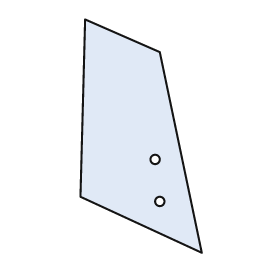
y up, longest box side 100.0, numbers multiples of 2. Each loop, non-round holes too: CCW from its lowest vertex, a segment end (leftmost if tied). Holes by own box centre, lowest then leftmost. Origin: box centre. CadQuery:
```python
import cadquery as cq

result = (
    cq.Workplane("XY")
    .moveTo(26.0, -50.0)
    .lineTo(8.0, 36.0)
    .lineTo(-24.0, 50.0)
    .lineTo(-26.0, -26.0)
    .close()
    .moveTo(8.0, -28.0)
    .circle(2.0)
    .moveTo(6.0, -10.0)
    .circle(2.0)
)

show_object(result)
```